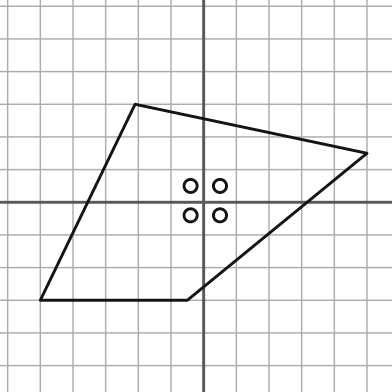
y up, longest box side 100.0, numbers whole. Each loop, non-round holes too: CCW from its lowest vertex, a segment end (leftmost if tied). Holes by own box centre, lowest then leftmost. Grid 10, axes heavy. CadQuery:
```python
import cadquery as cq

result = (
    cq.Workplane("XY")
    .moveTo(-50.0, -30.0)
    .lineTo(-5.0, -30.0)
    .lineTo(50.0, 15.0)
    .lineTo(-21.0, 30.0)
    .close()
    .moveTo(-4.0, -4.0)
    .circle(2.0)
    .moveTo(5.0, -4.0)
    .circle(2.0)
    .moveTo(-4.0, 5.0)
    .circle(2.0)
    .moveTo(5.0, 5.0)
    .circle(2.0)
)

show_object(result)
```